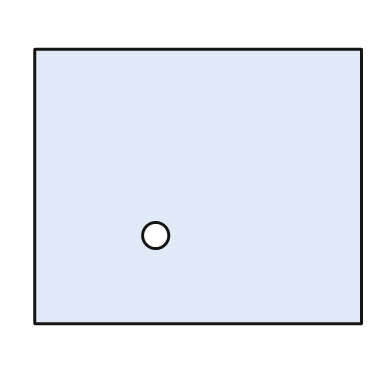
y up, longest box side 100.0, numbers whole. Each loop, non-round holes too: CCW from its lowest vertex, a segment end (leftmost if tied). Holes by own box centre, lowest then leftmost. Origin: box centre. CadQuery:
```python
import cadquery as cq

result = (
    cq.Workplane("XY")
    .moveTo(-50.0, -42.0)
    .lineTo(50.0, -42.0)
    .lineTo(50.0, 42.0)
    .lineTo(-50.0, 42.0)
    .close()
    .moveTo(-13.0, -15.0)
    .circle(4.0)
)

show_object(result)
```